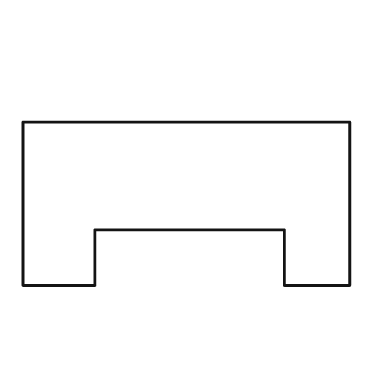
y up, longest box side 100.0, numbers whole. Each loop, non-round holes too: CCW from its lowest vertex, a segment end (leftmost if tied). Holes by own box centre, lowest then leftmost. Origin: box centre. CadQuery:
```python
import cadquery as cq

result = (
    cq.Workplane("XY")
    .moveTo(-50.0, -25.0)
    .lineTo(-28.0, -25.0)
    .lineTo(-28.0, -8.0)
    .lineTo(30.0, -8.0)
    .lineTo(30.0, -25.0)
    .lineTo(50.0, -25.0)
    .lineTo(50.0, 25.0)
    .lineTo(-50.0, 25.0)
    .close()
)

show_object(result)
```